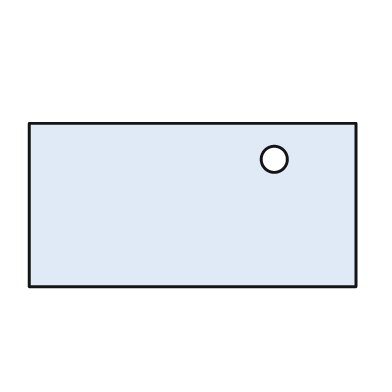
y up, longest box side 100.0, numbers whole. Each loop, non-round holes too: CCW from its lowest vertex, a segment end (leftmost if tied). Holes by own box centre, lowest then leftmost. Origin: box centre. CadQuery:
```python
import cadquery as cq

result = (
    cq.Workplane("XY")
    .moveTo(-50.0, -25.0)
    .lineTo(50.0, -25.0)
    .lineTo(50.0, 25.0)
    .lineTo(-50.0, 25.0)
    .close()
    .moveTo(25.0, 14.0)
    .circle(4.0)
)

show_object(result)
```